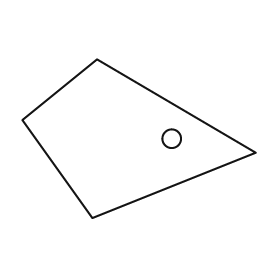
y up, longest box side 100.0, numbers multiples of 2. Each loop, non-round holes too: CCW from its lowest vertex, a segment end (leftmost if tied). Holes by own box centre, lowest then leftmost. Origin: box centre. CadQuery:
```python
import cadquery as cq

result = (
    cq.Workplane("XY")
    .moveTo(-20.0, -34.0)
    .lineTo(50.0, -6.0)
    .lineTo(-18.0, 34.0)
    .lineTo(-50.0, 8.0)
    .close()
    .moveTo(14.0, 0.0)
    .circle(4.0)
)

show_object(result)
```